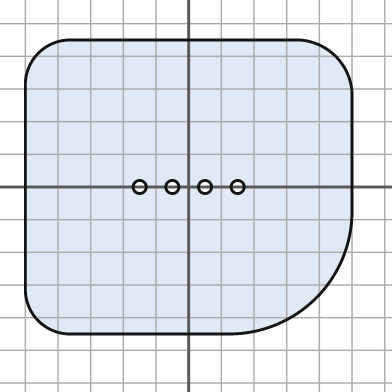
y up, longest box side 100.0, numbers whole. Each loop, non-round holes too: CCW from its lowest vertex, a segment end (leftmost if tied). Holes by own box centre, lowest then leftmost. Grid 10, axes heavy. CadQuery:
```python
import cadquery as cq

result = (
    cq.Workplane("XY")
    .moveTo(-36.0, -45.0)
    .lineTo(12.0, -45.0)
    .threePointArc((39.0, -34.0), (50.0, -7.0))
    .lineTo(50.0, 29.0)
    .threePointArc((45.0, 40.0), (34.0, 45.0))
    .lineTo(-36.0, 45.0)
    .threePointArc((-46.0, 41.0), (-50.0, 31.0))
    .lineTo(-50.0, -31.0)
    .threePointArc((-46.0, -41.0), (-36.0, -45.0))
    .close()
    .moveTo(-15.0, 0.0)
    .circle(2.0)
    .moveTo(-5.0, 0.0)
    .circle(2.0)
    .moveTo(5.0, 0.0)
    .circle(2.0)
    .moveTo(15.0, 0.0)
    .circle(2.0)
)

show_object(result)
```